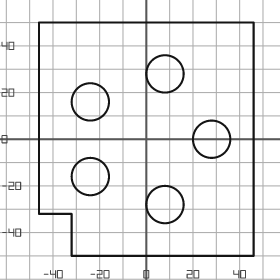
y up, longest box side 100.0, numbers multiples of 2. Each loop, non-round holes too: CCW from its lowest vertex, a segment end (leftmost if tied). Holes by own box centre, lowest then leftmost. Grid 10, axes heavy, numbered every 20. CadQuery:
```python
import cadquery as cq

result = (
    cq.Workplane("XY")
    .moveTo(-32.0, -50.0)
    .lineTo(46.0, -50.0)
    .lineTo(46.0, 50.0)
    .lineTo(-46.0, 50.0)
    .lineTo(-46.0, -32.0)
    .lineTo(-32.0, -32.0)
    .close()
    .moveTo(8.0, -28.0)
    .circle(8.0)
    .moveTo(-24.0, -16.0)
    .circle(8.0)
    .moveTo(28.0, 0.0)
    .circle(8.0)
    .moveTo(-24.0, 16.0)
    .circle(8.0)
    .moveTo(8.0, 28.0)
    .circle(8.0)
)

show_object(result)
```